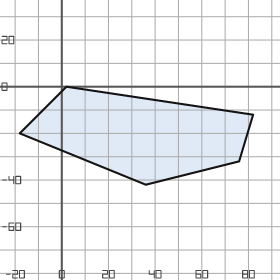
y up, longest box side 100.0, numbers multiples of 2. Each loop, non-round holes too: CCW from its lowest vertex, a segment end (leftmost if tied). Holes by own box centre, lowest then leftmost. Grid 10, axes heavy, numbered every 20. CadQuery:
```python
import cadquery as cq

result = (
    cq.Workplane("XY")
    .moveTo(36.0, -42.0)
    .lineTo(76.0, -32.0)
    .lineTo(82.0, -12.0)
    .lineTo(2.0, 0.0)
    .lineTo(-18.0, -20.0)
    .close()
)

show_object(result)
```